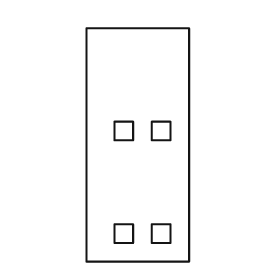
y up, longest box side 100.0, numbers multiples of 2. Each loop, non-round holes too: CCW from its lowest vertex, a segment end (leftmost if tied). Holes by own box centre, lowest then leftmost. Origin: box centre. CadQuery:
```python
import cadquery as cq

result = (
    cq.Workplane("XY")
    .moveTo(-22.0, -50.0)
    .lineTo(22.0, -50.0)
    .lineTo(22.0, 50.0)
    .lineTo(-22.0, 50.0)
    .close()
    .moveTo(-10.0, -42.0)
    .lineTo(-2.0, -42.0)
    .lineTo(-2.0, -34.0)
    .lineTo(-10.0, -34.0)
    .close()
    .moveTo(6.0, -42.0)
    .lineTo(14.0, -42.0)
    .lineTo(14.0, -34.0)
    .lineTo(6.0, -34.0)
    .close()
    .moveTo(-10.0, 2.0)
    .lineTo(-2.0, 2.0)
    .lineTo(-2.0, 10.0)
    .lineTo(-10.0, 10.0)
    .close()
    .moveTo(6.0, 2.0)
    .lineTo(14.0, 2.0)
    .lineTo(14.0, 10.0)
    .lineTo(6.0, 10.0)
    .close()
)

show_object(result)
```